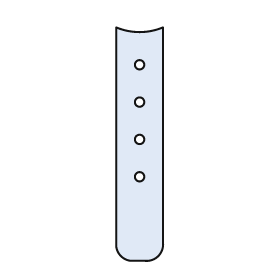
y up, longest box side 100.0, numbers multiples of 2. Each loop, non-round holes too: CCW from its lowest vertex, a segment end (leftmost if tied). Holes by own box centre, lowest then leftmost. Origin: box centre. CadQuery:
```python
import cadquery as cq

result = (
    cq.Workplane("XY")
    .moveTo(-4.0, -50.0)
    .lineTo(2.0, -50.0)
    .threePointArc((8.0, -48.0), (10.0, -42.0))
    .lineTo(10.0, 50.0)
    .threePointArc((0.0, 48.0), (-10.0, 50.0))
    .lineTo(-10.0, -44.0)
    .threePointArc((-8.0, -48.0), (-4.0, -50.0))
    .close()
    .moveTo(0.0, -14.0)
    .circle(2.0)
    .moveTo(0.0, 2.0)
    .circle(2.0)
    .moveTo(0.0, 18.0)
    .circle(2.0)
    .moveTo(0.0, 34.0)
    .circle(2.0)
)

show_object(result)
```